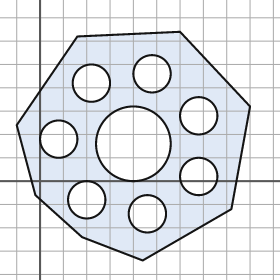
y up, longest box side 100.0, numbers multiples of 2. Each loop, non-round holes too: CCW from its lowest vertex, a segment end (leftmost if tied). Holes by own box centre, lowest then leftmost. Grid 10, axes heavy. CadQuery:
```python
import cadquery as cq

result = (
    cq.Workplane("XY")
    .moveTo(44.0, -34.0)
    .lineTo(82.0, -12.0)
    .lineTo(90.0, 32.0)
    .lineTo(60.0, 64.0)
    .lineTo(16.0, 62.0)
    .lineTo(-10.0, 24.0)
    .lineTo(-2.0, -6.0)
    .lineTo(18.0, -24.0)
    .close()
    .moveTo(46.0, -14.0)
    .circle(8.0)
    .moveTo(20.0, -8.0)
    .circle(8.0)
    .moveTo(68.0, 2.0)
    .circle(8.0)
    .moveTo(40.0, 16.0)
    .circle(16.0)
    .moveTo(8.0, 18.0)
    .circle(8.0)
    .moveTo(68.0, 28.0)
    .circle(8.0)
    .moveTo(22.0, 42.0)
    .circle(8.0)
    .moveTo(48.0, 46.0)
    .circle(8.0)
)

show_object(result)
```